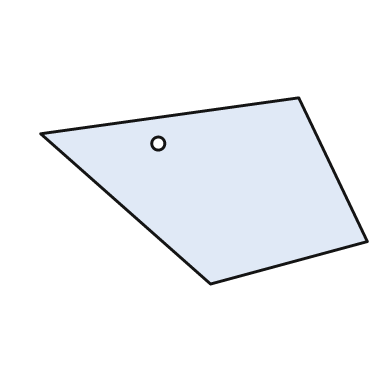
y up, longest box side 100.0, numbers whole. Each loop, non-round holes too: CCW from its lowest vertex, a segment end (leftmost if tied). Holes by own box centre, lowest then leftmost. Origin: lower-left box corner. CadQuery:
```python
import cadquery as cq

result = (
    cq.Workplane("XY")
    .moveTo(52.0, 0.0)
    .lineTo(100.0, 13.0)
    .lineTo(79.0, 57.0)
    .lineTo(0.0, 46.0)
    .close()
    .moveTo(36.0, 43.0)
    .circle(2.0)
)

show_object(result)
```